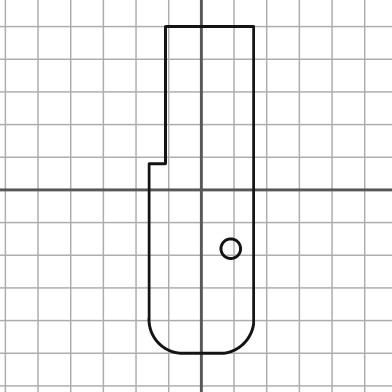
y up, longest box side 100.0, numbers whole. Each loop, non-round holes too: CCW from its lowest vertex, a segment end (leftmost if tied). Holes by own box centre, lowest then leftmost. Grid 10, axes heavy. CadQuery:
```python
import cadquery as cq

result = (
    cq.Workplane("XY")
    .moveTo(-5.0, -50.0)
    .lineTo(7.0, -50.0)
    .threePointArc((13.0, -47.0), (16.0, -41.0))
    .lineTo(16.0, 50.0)
    .lineTo(-11.0, 50.0)
    .lineTo(-11.0, 8.0)
    .lineTo(-16.0, 8.0)
    .lineTo(-16.0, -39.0)
    .threePointArc((-13.0, -47.0), (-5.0, -50.0))
    .close()
    .moveTo(9.0, -18.0)
    .circle(3.0)
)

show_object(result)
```